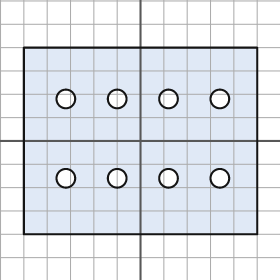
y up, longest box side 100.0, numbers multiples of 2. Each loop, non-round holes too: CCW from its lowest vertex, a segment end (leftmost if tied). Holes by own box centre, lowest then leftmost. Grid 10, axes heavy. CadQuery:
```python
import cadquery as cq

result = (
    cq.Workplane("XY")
    .moveTo(-50.0, -40.0)
    .lineTo(50.0, -40.0)
    .lineTo(50.0, 40.0)
    .lineTo(-50.0, 40.0)
    .close()
    .moveTo(-32.0, -16.0)
    .circle(4.0)
    .moveTo(-10.0, -16.0)
    .circle(4.0)
    .moveTo(12.0, -16.0)
    .circle(4.0)
    .moveTo(34.0, -16.0)
    .circle(4.0)
    .moveTo(-32.0, 18.0)
    .circle(4.0)
    .moveTo(-10.0, 18.0)
    .circle(4.0)
    .moveTo(12.0, 18.0)
    .circle(4.0)
    .moveTo(34.0, 18.0)
    .circle(4.0)
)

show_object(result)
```